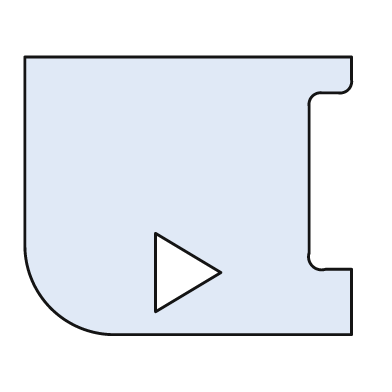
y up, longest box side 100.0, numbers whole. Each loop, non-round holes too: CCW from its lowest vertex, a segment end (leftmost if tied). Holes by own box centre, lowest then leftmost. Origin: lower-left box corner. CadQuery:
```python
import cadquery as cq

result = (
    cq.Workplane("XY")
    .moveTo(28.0, 0.0)
    .lineTo(100.0, 0.0)
    .lineTo(100.0, 20.0)
    .lineTo(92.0, 20.0)
    .threePointArc((88.0, 21.0), (87.0, 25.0))
    .lineTo(87.0, 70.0)
    .threePointArc((88.0, 73.0), (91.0, 74.0))
    .lineTo(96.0, 74.0)
    .threePointArc((99.0, 75.0), (100.0, 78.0))
    .lineTo(100.0, 85.0)
    .lineTo(0.0, 85.0)
    .lineTo(0.0, 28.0)
    .threePointArc((8.0, 8.0), (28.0, 0.0))
    .close()
    .moveTo(40.0, 7.0)
    .lineTo(60.0, 19.0)
    .lineTo(40.0, 31.0)
    .close()
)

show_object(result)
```